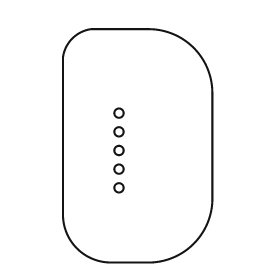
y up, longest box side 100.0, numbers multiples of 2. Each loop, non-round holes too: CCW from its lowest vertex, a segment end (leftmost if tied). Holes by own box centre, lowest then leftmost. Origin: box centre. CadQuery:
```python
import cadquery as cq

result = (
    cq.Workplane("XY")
    .moveTo(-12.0, -50.0)
    .lineTo(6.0, -50.0)
    .threePointArc((24.0, -42.0), (32.0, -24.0))
    .lineTo(32.0, 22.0)
    .threePointArc((24.0, 42.0), (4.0, 50.0))
    .lineTo(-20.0, 50.0)
    .threePointArc((-28.0, 46.0), (-32.0, 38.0))
    .lineTo(-32.0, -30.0)
    .threePointArc((-26.0, -44.0), (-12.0, -50.0))
    .close()
    .moveTo(-8.0, -18.0)
    .circle(2.0)
    .moveTo(-8.0, -10.0)
    .circle(2.0)
    .moveTo(-8.0, -2.0)
    .circle(2.0)
    .moveTo(-8.0, 6.0)
    .circle(2.0)
    .moveTo(-8.0, 14.0)
    .circle(2.0)
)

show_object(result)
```